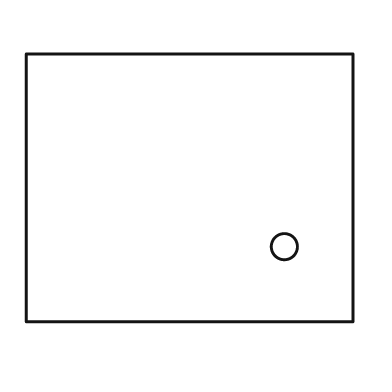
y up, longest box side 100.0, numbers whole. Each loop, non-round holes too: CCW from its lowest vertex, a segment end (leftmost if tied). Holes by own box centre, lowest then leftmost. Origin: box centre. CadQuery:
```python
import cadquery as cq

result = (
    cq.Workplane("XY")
    .moveTo(-50.0, -41.0)
    .lineTo(50.0, -41.0)
    .lineTo(50.0, 41.0)
    .lineTo(-50.0, 41.0)
    .close()
    .moveTo(29.0, -18.0)
    .circle(4.0)
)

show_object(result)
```